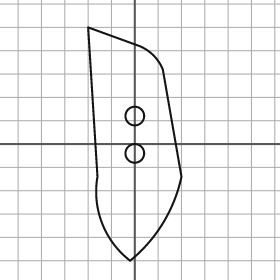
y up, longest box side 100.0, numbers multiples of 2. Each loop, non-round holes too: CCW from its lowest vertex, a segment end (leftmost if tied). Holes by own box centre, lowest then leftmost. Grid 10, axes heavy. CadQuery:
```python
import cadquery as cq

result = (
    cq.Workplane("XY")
    .moveTo(-2.0, -50.0)
    .threePointArc((12.0, -34.0), (20.0, -14.0))
    .lineTo(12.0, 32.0)
    .threePointArc((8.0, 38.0), (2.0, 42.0))
    .lineTo(-20.0, 50.0)
    .lineTo(-16.0, -14.0)
    .threePointArc((-14.0, -34.0), (-2.0, -50.0))
    .close()
    .moveTo(0.0, -4.0)
    .circle(4.0)
    .moveTo(0.0, 12.0)
    .circle(4.0)
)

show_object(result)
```